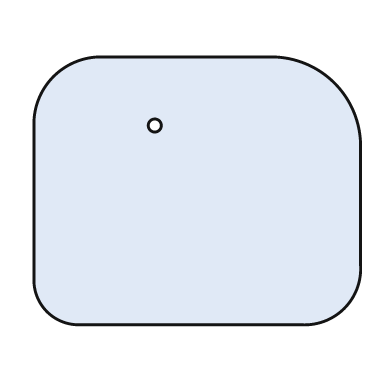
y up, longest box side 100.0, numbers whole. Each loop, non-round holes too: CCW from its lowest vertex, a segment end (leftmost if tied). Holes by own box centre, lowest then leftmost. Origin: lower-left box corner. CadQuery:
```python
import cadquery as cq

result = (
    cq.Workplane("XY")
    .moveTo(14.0, 0.0)
    .lineTo(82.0, 0.0)
    .threePointArc((95.0, 5.0), (100.0, 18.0))
    .lineTo(100.0, 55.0)
    .threePointArc((92.0, 74.0), (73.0, 82.0))
    .lineTo(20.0, 82.0)
    .threePointArc((6.0, 76.0), (0.0, 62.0))
    .lineTo(0.0, 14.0)
    .threePointArc((4.0, 4.0), (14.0, 0.0))
    .close()
    .moveTo(37.0, 61.0)
    .circle(2.0)
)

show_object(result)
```